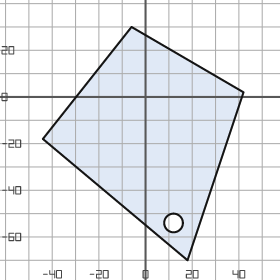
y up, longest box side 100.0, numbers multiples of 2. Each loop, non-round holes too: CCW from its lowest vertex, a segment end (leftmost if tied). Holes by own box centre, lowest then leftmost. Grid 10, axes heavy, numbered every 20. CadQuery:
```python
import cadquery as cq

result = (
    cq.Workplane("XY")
    .moveTo(18.0, -70.0)
    .lineTo(42.0, 2.0)
    .lineTo(-6.0, 30.0)
    .lineTo(-44.0, -18.0)
    .close()
    .moveTo(12.0, -54.0)
    .circle(4.0)
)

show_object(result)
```